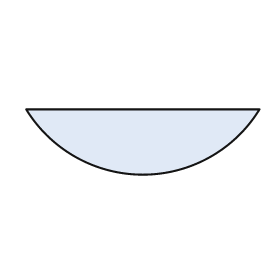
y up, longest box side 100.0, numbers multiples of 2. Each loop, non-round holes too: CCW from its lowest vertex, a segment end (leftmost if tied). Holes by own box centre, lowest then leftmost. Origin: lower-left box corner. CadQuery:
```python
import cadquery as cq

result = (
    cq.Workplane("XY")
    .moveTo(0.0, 28.0)
    .threePointArc((50.0, 0.0), (100.0, 28.0))
    .close()
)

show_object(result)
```